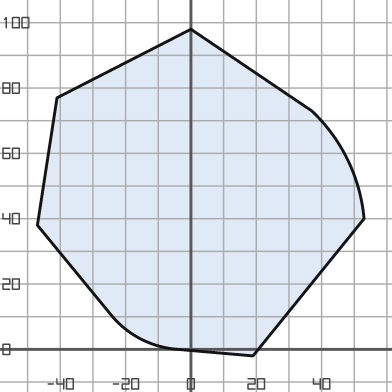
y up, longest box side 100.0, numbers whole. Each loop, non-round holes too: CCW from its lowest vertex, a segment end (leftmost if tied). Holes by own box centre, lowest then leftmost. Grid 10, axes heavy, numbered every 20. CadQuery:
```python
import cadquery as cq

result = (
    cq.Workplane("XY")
    .moveTo(19.0, -2.0)
    .lineTo(53.0, 40.0)
    .threePointArc((48.0, 58.0), (37.0, 73.0))
    .lineTo(0.0, 98.0)
    .lineTo(-41.0, 77.0)
    .lineTo(-47.0, 38.0)
    .lineTo(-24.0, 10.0)
    .threePointArc((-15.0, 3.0), (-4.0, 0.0))
    .close()
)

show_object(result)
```